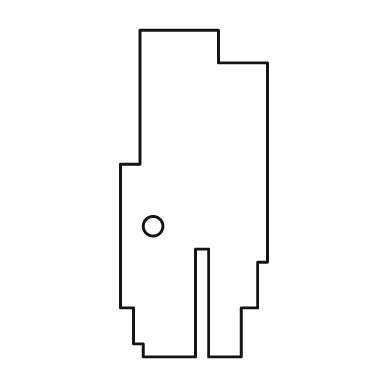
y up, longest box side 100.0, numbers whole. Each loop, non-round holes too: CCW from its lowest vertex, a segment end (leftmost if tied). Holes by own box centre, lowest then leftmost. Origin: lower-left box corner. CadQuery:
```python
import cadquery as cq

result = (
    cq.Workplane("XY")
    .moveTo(7.0, 0.0)
    .lineTo(23.0, 0.0)
    .lineTo(23.0, 33.0)
    .lineTo(27.0, 33.0)
    .lineTo(27.0, 0.0)
    .lineTo(37.0, 0.0)
    .lineTo(37.0, 15.0)
    .lineTo(42.0, 15.0)
    .lineTo(42.0, 29.0)
    .lineTo(45.0, 29.0)
    .lineTo(45.0, 90.0)
    .lineTo(30.0, 90.0)
    .lineTo(30.0, 100.0)
    .lineTo(6.0, 100.0)
    .lineTo(6.0, 59.0)
    .lineTo(0.0, 59.0)
    .lineTo(0.0, 15.0)
    .lineTo(4.0, 15.0)
    .lineTo(4.0, 4.0)
    .lineTo(7.0, 4.0)
    .close()
    .moveTo(10.0, 40.0)
    .circle(3.0)
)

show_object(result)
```